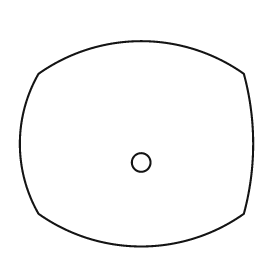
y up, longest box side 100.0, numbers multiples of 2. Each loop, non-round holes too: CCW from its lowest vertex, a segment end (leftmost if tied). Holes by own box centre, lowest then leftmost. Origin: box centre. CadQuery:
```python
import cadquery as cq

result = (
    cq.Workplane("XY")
    .moveTo(-42.0, -30.0)
    .threePointArc((2.0, -44.0), (46.0, -30.0))
    .threePointArc((50.0, 0.0), (46.0, 30.0))
    .threePointArc((2.0, 44.0), (-42.0, 30.0))
    .threePointArc((-50.0, 0.0), (-42.0, -30.0))
    .close()
    .moveTo(2.0, -8.0)
    .circle(4.0)
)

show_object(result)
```